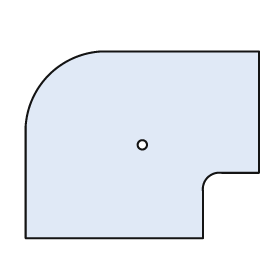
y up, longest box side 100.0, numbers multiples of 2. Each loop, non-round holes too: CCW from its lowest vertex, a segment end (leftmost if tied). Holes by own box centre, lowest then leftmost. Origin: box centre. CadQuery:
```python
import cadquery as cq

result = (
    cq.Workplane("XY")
    .moveTo(-50.0, -40.0)
    .lineTo(26.0, -40.0)
    .lineTo(26.0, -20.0)
    .threePointArc((28.0, -14.0), (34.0, -12.0))
    .lineTo(50.0, -12.0)
    .lineTo(50.0, 40.0)
    .lineTo(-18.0, 40.0)
    .threePointArc((-40.0, 30.0), (-50.0, 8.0))
    .close()
    .moveTo(0.0, 0.0)
    .circle(2.0)
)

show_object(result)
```